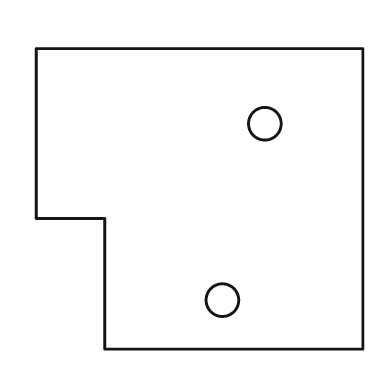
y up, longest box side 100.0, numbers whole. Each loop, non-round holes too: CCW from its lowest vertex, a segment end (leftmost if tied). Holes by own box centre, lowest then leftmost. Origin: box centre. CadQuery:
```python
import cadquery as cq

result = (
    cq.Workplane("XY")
    .moveTo(-29.0, -46.0)
    .lineTo(50.0, -46.0)
    .lineTo(50.0, 46.0)
    .lineTo(-50.0, 46.0)
    .lineTo(-50.0, -6.0)
    .lineTo(-29.0, -6.0)
    .close()
    .moveTo(7.0, -31.0)
    .circle(5.0)
    .moveTo(20.0, 23.0)
    .circle(5.0)
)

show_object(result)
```